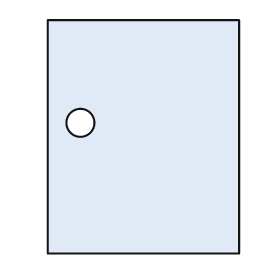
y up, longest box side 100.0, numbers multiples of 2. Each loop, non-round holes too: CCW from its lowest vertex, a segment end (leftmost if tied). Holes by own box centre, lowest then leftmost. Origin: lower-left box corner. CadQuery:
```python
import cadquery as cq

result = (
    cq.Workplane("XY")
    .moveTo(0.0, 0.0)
    .lineTo(82.0, 0.0)
    .lineTo(82.0, 100.0)
    .lineTo(0.0, 100.0)
    .close()
    .moveTo(14.0, 56.0)
    .circle(6.0)
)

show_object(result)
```